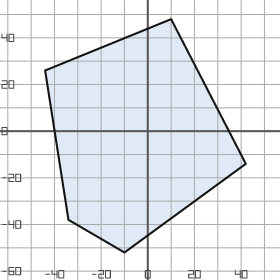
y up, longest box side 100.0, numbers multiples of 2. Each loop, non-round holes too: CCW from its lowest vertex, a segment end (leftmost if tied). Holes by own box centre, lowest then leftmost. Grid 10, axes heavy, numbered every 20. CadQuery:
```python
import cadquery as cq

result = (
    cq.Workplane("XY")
    .moveTo(-10.0, -52.0)
    .lineTo(42.0, -14.0)
    .lineTo(10.0, 48.0)
    .lineTo(-44.0, 26.0)
    .lineTo(-34.0, -38.0)
    .close()
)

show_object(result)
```